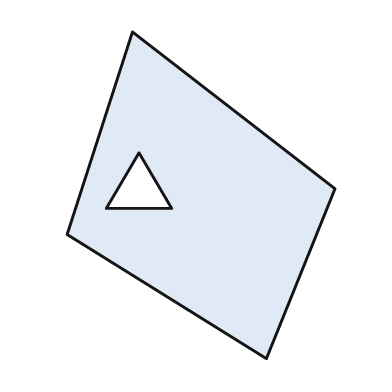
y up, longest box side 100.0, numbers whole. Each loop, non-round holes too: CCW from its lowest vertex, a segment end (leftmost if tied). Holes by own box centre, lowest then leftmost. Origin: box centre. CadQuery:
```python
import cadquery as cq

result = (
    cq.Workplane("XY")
    .moveTo(20.0, -50.0)
    .lineTo(41.0, 2.0)
    .lineTo(-21.0, 50.0)
    .lineTo(-41.0, -12.0)
    .close()
    .moveTo(-29.0, -4.0)
    .lineTo(-9.0, -4.0)
    .lineTo(-19.0, 13.0)
    .close()
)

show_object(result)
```